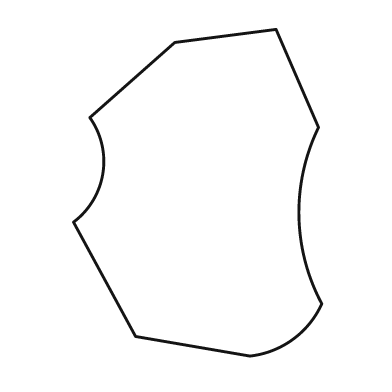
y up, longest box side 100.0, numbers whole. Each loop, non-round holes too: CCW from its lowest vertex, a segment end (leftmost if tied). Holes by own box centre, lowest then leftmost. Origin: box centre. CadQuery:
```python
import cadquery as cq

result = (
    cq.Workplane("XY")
    .moveTo(16.0, -50.0)
    .threePointArc((29.0, -45.0), (38.0, -34.0))
    .threePointArc((31.0, -7.0), (37.0, 20.0))
    .lineTo(24.0, 50.0)
    .lineTo(-7.0, 46.0)
    .lineTo(-33.0, 23.0)
    .threePointArc((-29.0, 6.0), (-38.0, -9.0))
    .lineTo(-19.0, -44.0)
    .close()
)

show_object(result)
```